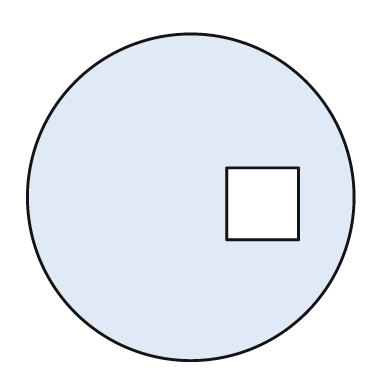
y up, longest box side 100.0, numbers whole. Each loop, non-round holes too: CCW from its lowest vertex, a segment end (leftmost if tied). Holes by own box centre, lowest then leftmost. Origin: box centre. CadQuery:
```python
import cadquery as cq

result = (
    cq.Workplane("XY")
    .moveTo(0.0, 0.0)
    .circle(50.0)
    .moveTo(11.0, -13.0)
    .lineTo(33.0, -13.0)
    .lineTo(33.0, 9.0)
    .lineTo(11.0, 9.0)
    .close()
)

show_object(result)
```